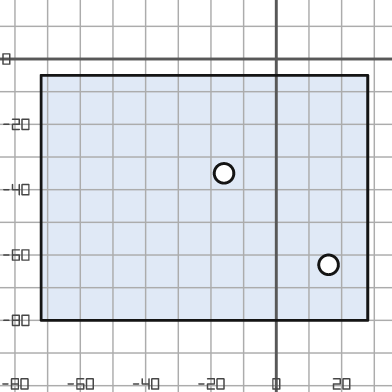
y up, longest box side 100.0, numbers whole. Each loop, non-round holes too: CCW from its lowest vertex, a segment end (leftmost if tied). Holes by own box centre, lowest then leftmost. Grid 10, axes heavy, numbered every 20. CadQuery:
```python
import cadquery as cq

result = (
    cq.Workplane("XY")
    .moveTo(-72.0, -80.0)
    .lineTo(28.0, -80.0)
    .lineTo(28.0, -5.0)
    .lineTo(-72.0, -5.0)
    .close()
    .moveTo(16.0, -63.0)
    .circle(3.0)
    .moveTo(-16.0, -35.0)
    .circle(3.0)
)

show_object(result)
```